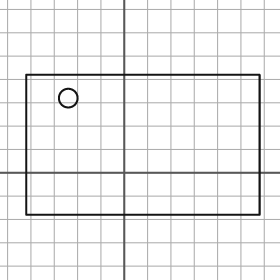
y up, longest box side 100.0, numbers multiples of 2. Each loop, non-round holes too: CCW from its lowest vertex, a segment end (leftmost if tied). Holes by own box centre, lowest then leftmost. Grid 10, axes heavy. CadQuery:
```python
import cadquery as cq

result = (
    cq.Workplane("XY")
    .moveTo(-42.0, -18.0)
    .lineTo(58.0, -18.0)
    .lineTo(58.0, 42.0)
    .lineTo(-42.0, 42.0)
    .close()
    .moveTo(-24.0, 32.0)
    .circle(4.0)
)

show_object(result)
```